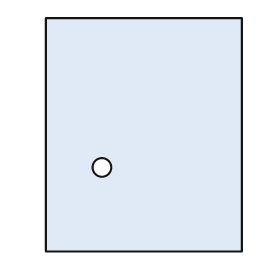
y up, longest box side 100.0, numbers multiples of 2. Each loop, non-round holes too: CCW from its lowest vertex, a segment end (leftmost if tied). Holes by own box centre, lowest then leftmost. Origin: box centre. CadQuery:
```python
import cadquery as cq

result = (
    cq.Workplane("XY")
    .moveTo(-42.0, -50.0)
    .lineTo(42.0, -50.0)
    .lineTo(42.0, 50.0)
    .lineTo(-42.0, 50.0)
    .close()
    .moveTo(-18.0, -14.0)
    .circle(4.0)
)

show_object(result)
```